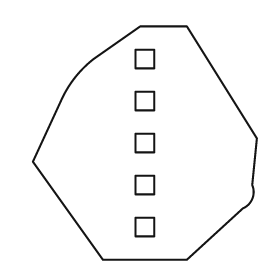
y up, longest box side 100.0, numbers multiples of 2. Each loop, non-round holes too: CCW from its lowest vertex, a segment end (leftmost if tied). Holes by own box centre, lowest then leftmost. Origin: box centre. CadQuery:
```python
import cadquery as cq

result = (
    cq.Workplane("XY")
    .moveTo(-18.0, -50.0)
    .lineTo(18.0, -50.0)
    .lineTo(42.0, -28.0)
    .threePointArc((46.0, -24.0), (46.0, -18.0))
    .lineTo(48.0, 2.0)
    .lineTo(18.0, 50.0)
    .lineTo(-2.0, 50.0)
    .lineTo(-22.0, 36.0)
    .threePointArc((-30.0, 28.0), (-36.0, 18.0))
    .lineTo(-48.0, -8.0)
    .close()
    .moveTo(-4.0, -40.0)
    .lineTo(4.0, -40.0)
    .lineTo(4.0, -32.0)
    .lineTo(-4.0, -32.0)
    .close()
    .moveTo(-4.0, -22.0)
    .lineTo(4.0, -22.0)
    .lineTo(4.0, -14.0)
    .lineTo(-4.0, -14.0)
    .close()
    .moveTo(-4.0, -4.0)
    .lineTo(4.0, -4.0)
    .lineTo(4.0, 4.0)
    .lineTo(-4.0, 4.0)
    .close()
    .moveTo(-4.0, 14.0)
    .lineTo(4.0, 14.0)
    .lineTo(4.0, 22.0)
    .lineTo(-4.0, 22.0)
    .close()
    .moveTo(-4.0, 32.0)
    .lineTo(4.0, 32.0)
    .lineTo(4.0, 40.0)
    .lineTo(-4.0, 40.0)
    .close()
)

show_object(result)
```